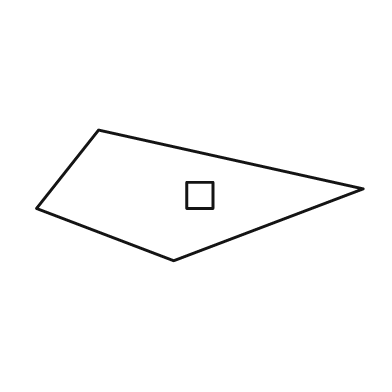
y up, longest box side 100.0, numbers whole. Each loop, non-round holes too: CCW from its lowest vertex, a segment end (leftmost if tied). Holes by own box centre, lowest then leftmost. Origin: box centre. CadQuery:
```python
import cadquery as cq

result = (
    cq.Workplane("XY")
    .moveTo(-8.0, -20.0)
    .lineTo(50.0, 2.0)
    .lineTo(-31.0, 20.0)
    .lineTo(-50.0, -4.0)
    .close()
    .moveTo(-4.0, -4.0)
    .lineTo(4.0, -4.0)
    .lineTo(4.0, 4.0)
    .lineTo(-4.0, 4.0)
    .close()
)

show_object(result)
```